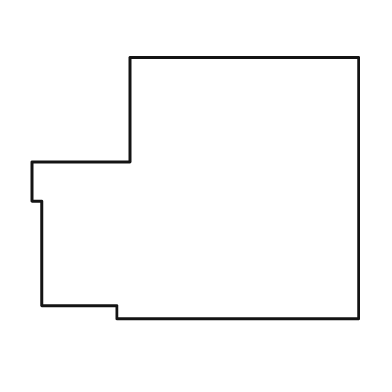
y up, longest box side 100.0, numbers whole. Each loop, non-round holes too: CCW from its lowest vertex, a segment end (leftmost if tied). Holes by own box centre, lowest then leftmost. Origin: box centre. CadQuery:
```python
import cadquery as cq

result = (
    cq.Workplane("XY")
    .moveTo(-24.0, -40.0)
    .lineTo(50.0, -40.0)
    .lineTo(50.0, 40.0)
    .lineTo(-20.0, 40.0)
    .lineTo(-20.0, 8.0)
    .lineTo(-50.0, 8.0)
    .lineTo(-50.0, -4.0)
    .lineTo(-47.0, -4.0)
    .lineTo(-47.0, -36.0)
    .lineTo(-24.0, -36.0)
    .close()
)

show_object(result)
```